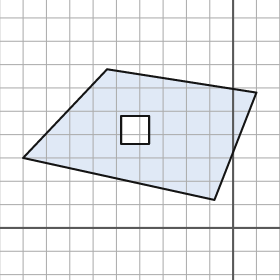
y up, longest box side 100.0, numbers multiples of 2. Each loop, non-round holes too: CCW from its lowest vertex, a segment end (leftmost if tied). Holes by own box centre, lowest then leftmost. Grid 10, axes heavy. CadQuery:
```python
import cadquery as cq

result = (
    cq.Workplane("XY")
    .moveTo(-8.0, 12.0)
    .lineTo(10.0, 58.0)
    .lineTo(-54.0, 68.0)
    .lineTo(-90.0, 30.0)
    .close()
    .moveTo(-48.0, 36.0)
    .lineTo(-36.0, 36.0)
    .lineTo(-36.0, 48.0)
    .lineTo(-48.0, 48.0)
    .close()
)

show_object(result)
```